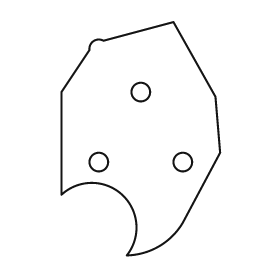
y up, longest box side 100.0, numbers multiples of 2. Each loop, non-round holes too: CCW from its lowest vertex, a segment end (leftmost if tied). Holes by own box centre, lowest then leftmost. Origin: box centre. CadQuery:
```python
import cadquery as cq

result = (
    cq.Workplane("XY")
    .moveTo(-6.0, -50.0)
    .threePointArc((8.0, -46.0), (18.0, -36.0))
    .lineTo(34.0, -6.0)
    .lineTo(32.0, 18.0)
    .lineTo(14.0, 50.0)
    .lineTo(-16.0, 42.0)
    .threePointArc((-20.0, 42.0), (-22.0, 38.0))
    .lineTo(-34.0, 20.0)
    .lineTo(-34.0, -24.0)
    .threePointArc((-8.0, -24.0), (-6.0, -50.0))
    .close()
    .moveTo(-18.0, -10.0)
    .circle(4.0)
    .moveTo(18.0, -10.0)
    .circle(4.0)
    .moveTo(0.0, 20.0)
    .circle(4.0)
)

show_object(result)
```